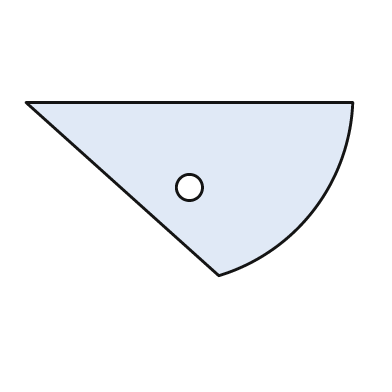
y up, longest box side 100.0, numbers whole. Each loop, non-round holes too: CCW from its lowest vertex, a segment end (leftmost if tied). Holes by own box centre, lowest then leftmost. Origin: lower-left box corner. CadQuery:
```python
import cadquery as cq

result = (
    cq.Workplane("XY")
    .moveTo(59.0, 0.0)
    .threePointArc((88.0, 20.0), (100.0, 53.0))
    .lineTo(0.0, 53.0)
    .close()
    .moveTo(50.0, 27.0)
    .circle(4.0)
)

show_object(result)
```